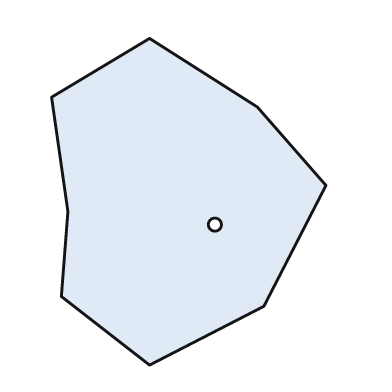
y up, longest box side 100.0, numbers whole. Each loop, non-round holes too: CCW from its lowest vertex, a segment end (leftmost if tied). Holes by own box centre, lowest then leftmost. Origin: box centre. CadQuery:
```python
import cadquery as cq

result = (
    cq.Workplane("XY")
    .moveTo(-12.0, -50.0)
    .lineTo(23.0, -32.0)
    .lineTo(42.0, 5.0)
    .lineTo(21.0, 29.0)
    .lineTo(-12.0, 50.0)
    .lineTo(-42.0, 32.0)
    .lineTo(-37.0, -3.0)
    .lineTo(-39.0, -29.0)
    .close()
    .moveTo(8.0, -7.0)
    .circle(2.0)
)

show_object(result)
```